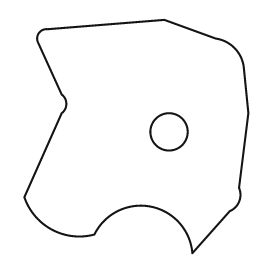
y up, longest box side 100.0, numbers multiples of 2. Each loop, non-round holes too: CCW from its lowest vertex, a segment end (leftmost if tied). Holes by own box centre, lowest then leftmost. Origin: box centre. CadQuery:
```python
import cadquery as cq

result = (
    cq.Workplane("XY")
    .moveTo(24.0, -50.0)
    .lineTo(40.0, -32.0)
    .threePointArc((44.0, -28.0), (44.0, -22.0))
    .lineTo(48.0, 10.0)
    .lineTo(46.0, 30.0)
    .threePointArc((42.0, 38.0), (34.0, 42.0))
    .lineTo(12.0, 50.0)
    .lineTo(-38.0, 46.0)
    .threePointArc((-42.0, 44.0), (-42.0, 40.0))
    .lineTo(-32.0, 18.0)
    .threePointArc((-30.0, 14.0), (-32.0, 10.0))
    .lineTo(-48.0, -26.0)
    .threePointArc((-36.0, -40.0), (-18.0, -42.0))
    .threePointArc((6.0, -30.0), (24.0, -50.0))
    .close()
    .moveTo(14.0, 2.0)
    .circle(8.0)
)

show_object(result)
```